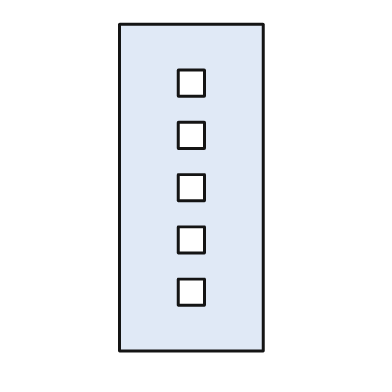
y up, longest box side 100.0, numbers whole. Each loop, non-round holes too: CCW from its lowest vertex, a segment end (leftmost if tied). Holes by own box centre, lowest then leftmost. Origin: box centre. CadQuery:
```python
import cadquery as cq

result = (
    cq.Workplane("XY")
    .moveTo(-22.0, -50.0)
    .lineTo(22.0, -50.0)
    .lineTo(22.0, 50.0)
    .lineTo(-22.0, 50.0)
    .close()
    .moveTo(-4.0, -36.0)
    .lineTo(4.0, -36.0)
    .lineTo(4.0, -28.0)
    .lineTo(-4.0, -28.0)
    .close()
    .moveTo(-4.0, -20.0)
    .lineTo(4.0, -20.0)
    .lineTo(4.0, -12.0)
    .lineTo(-4.0, -12.0)
    .close()
    .moveTo(-4.0, -4.0)
    .lineTo(4.0, -4.0)
    .lineTo(4.0, 4.0)
    .lineTo(-4.0, 4.0)
    .close()
    .moveTo(-4.0, 12.0)
    .lineTo(4.0, 12.0)
    .lineTo(4.0, 20.0)
    .lineTo(-4.0, 20.0)
    .close()
    .moveTo(-4.0, 28.0)
    .lineTo(4.0, 28.0)
    .lineTo(4.0, 36.0)
    .lineTo(-4.0, 36.0)
    .close()
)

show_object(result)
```